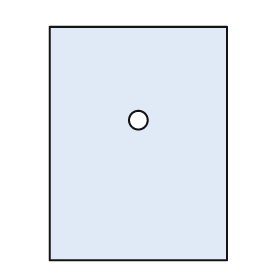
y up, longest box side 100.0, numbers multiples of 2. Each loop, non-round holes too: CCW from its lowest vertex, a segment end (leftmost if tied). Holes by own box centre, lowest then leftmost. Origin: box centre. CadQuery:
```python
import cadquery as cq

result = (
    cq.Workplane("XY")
    .moveTo(-38.0, -50.0)
    .lineTo(38.0, -50.0)
    .lineTo(38.0, 50.0)
    .lineTo(-38.0, 50.0)
    .close()
    .moveTo(0.0, 10.0)
    .circle(4.0)
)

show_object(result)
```